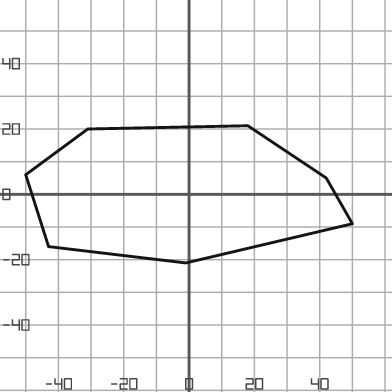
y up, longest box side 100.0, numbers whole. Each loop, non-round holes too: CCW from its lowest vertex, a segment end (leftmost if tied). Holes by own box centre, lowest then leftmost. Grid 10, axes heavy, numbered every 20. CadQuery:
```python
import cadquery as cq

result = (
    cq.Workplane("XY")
    .moveTo(-1.0, -21.0)
    .lineTo(50.0, -9.0)
    .lineTo(42.0, 5.0)
    .lineTo(18.0, 21.0)
    .lineTo(-31.0, 20.0)
    .lineTo(-50.0, 6.0)
    .lineTo(-43.0, -16.0)
    .close()
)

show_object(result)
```